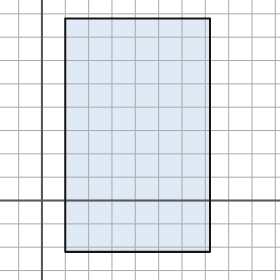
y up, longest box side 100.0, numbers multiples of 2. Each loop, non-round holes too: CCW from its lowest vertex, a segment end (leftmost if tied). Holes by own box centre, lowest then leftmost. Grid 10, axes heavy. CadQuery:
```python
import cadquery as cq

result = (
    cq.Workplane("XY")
    .moveTo(10.0, -22.0)
    .lineTo(72.0, -22.0)
    .lineTo(72.0, 78.0)
    .lineTo(10.0, 78.0)
    .close()
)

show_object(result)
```